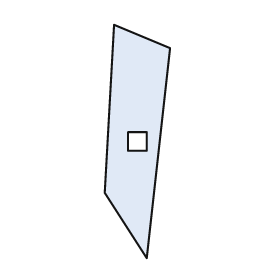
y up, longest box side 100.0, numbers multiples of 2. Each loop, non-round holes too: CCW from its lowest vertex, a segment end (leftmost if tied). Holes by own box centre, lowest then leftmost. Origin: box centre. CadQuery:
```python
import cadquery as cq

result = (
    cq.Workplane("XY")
    .moveTo(4.0, -50.0)
    .lineTo(14.0, 40.0)
    .lineTo(-10.0, 50.0)
    .lineTo(-14.0, -22.0)
    .close()
    .moveTo(-4.0, -4.0)
    .lineTo(4.0, -4.0)
    .lineTo(4.0, 4.0)
    .lineTo(-4.0, 4.0)
    .close()
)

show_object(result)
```